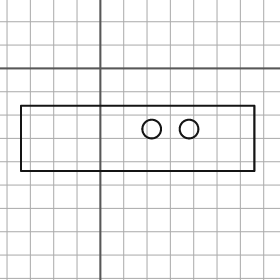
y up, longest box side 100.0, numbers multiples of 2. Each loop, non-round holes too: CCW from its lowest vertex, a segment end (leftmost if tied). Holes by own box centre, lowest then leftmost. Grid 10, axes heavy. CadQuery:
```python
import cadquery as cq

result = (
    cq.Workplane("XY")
    .moveTo(-34.0, -44.0)
    .lineTo(66.0, -44.0)
    .lineTo(66.0, -16.0)
    .lineTo(-34.0, -16.0)
    .close()
    .moveTo(22.0, -26.0)
    .circle(4.0)
    .moveTo(38.0, -26.0)
    .circle(4.0)
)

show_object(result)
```